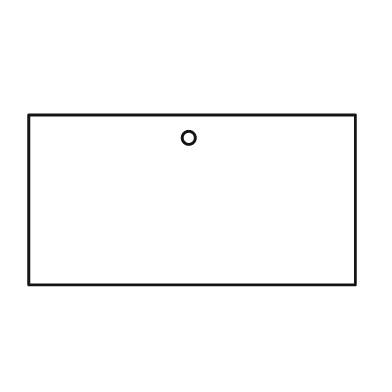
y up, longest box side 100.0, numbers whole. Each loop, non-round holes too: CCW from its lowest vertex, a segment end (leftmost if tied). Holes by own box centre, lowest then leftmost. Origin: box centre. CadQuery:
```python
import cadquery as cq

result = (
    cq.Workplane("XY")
    .moveTo(-50.0, -26.0)
    .lineTo(50.0, -26.0)
    .lineTo(50.0, 26.0)
    .lineTo(-50.0, 26.0)
    .close()
    .moveTo(-1.0, 19.0)
    .circle(2.0)
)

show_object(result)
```